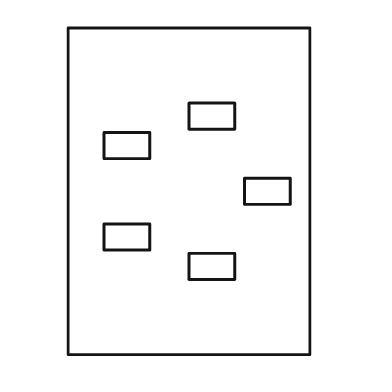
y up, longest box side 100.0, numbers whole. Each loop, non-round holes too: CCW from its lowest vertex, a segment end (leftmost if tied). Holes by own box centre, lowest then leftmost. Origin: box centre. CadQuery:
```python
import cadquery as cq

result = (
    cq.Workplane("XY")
    .moveTo(-37.0, -50.0)
    .lineTo(37.0, -50.0)
    .lineTo(37.0, 50.0)
    .lineTo(-37.0, 50.0)
    .close()
    .moveTo(0.0, -27.0)
    .lineTo(14.0, -27.0)
    .lineTo(14.0, -19.0)
    .lineTo(0.0, -19.0)
    .close()
    .moveTo(-26.0, -18.0)
    .lineTo(-12.0, -18.0)
    .lineTo(-12.0, -10.0)
    .lineTo(-26.0, -10.0)
    .close()
    .moveTo(17.0, -4.0)
    .lineTo(31.0, -4.0)
    .lineTo(31.0, 4.0)
    .lineTo(17.0, 4.0)
    .close()
    .moveTo(-26.0, 10.0)
    .lineTo(-12.0, 10.0)
    .lineTo(-12.0, 18.0)
    .lineTo(-26.0, 18.0)
    .close()
    .moveTo(0.0, 19.0)
    .lineTo(14.0, 19.0)
    .lineTo(14.0, 27.0)
    .lineTo(0.0, 27.0)
    .close()
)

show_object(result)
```